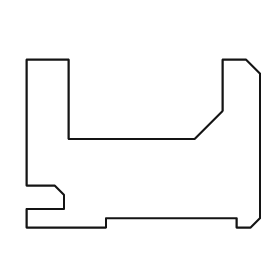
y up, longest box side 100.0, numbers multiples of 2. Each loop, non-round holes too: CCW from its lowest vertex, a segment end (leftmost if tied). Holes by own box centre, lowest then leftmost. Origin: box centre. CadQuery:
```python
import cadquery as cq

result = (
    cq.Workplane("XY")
    .moveTo(-50.0, -36.0)
    .lineTo(-16.0, -36.0)
    .lineTo(-16.0, -32.0)
    .lineTo(40.0, -32.0)
    .lineTo(40.0, -36.0)
    .lineTo(46.0, -36.0)
    .lineTo(50.0, -32.0)
    .lineTo(50.0, 30.0)
    .lineTo(44.0, 36.0)
    .lineTo(34.0, 36.0)
    .lineTo(34.0, 14.0)
    .lineTo(22.0, 2.0)
    .lineTo(-32.0, 2.0)
    .lineTo(-32.0, 36.0)
    .lineTo(-50.0, 36.0)
    .lineTo(-50.0, -18.0)
    .lineTo(-38.0, -18.0)
    .lineTo(-34.0, -22.0)
    .lineTo(-34.0, -28.0)
    .lineTo(-50.0, -28.0)
    .close()
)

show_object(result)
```